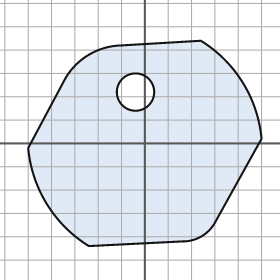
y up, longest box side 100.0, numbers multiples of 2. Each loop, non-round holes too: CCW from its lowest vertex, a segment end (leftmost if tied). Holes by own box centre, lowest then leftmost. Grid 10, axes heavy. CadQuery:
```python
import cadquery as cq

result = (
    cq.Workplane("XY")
    .moveTo(-24.0, -44.0)
    .lineTo(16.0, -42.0)
    .threePointArc((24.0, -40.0), (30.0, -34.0))
    .lineTo(50.0, 2.0)
    .threePointArc((42.0, 26.0), (24.0, 44.0))
    .lineTo(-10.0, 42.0)
    .threePointArc((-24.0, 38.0), (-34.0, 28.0))
    .lineTo(-50.0, -2.0)
    .threePointArc((-42.0, -26.0), (-24.0, -44.0))
    .close()
    .moveTo(-4.0, 22.0)
    .circle(8.0)
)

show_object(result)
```